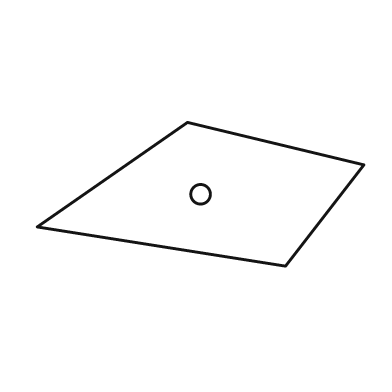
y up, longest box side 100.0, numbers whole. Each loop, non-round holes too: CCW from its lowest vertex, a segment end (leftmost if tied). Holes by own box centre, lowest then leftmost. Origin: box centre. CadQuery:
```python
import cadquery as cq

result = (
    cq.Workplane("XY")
    .moveTo(26.0, -22.0)
    .lineTo(50.0, 9.0)
    .lineTo(-4.0, 22.0)
    .lineTo(-50.0, -10.0)
    .close()
    .moveTo(0.0, 0.0)
    .circle(3.0)
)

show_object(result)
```